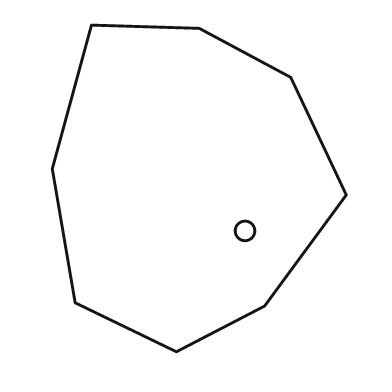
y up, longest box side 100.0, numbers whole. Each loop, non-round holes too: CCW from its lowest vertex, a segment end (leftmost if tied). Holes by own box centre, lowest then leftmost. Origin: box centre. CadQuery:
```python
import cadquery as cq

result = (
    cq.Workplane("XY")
    .moveTo(-7.0, -50.0)
    .lineTo(20.0, -36.0)
    .lineTo(45.0, -2.0)
    .lineTo(28.0, 34.0)
    .lineTo(0.0, 49.0)
    .lineTo(-33.0, 50.0)
    .lineTo(-45.0, 6.0)
    .lineTo(-38.0, -35.0)
    .close()
    .moveTo(14.0, -13.0)
    .circle(3.0)
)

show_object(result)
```